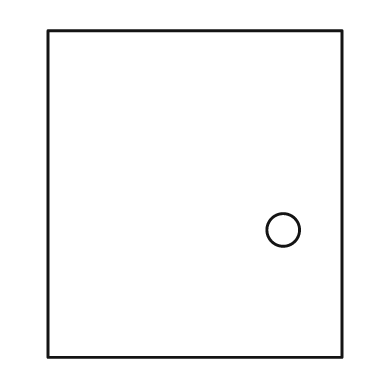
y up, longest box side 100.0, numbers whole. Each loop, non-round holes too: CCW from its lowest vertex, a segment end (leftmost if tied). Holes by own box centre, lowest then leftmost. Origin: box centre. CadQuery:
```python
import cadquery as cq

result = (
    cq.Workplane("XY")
    .moveTo(-45.0, -50.0)
    .lineTo(45.0, -50.0)
    .lineTo(45.0, 50.0)
    .lineTo(-45.0, 50.0)
    .close()
    .moveTo(27.0, -11.0)
    .circle(5.0)
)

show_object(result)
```